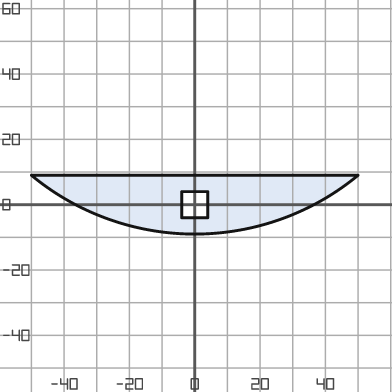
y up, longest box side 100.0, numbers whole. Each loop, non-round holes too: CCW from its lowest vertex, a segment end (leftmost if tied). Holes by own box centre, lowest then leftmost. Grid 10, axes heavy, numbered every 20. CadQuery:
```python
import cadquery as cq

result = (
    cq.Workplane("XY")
    .moveTo(-50.0, 9.0)
    .threePointArc((0.0, -9.0), (50.0, 9.0))
    .close()
    .moveTo(-4.0, -4.0)
    .lineTo(4.0, -4.0)
    .lineTo(4.0, 4.0)
    .lineTo(-4.0, 4.0)
    .close()
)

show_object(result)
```